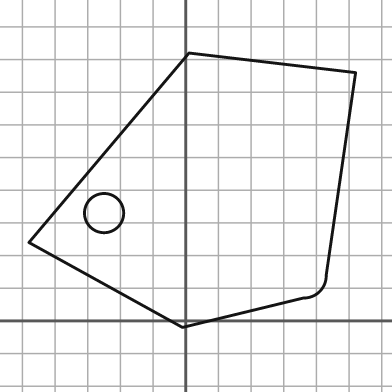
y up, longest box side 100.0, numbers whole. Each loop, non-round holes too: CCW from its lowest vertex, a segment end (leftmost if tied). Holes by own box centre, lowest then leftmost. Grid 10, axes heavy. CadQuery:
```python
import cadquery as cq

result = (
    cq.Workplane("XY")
    .moveTo(-1.0, -2.0)
    .lineTo(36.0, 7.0)
    .threePointArc((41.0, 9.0), (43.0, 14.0))
    .lineTo(52.0, 76.0)
    .lineTo(1.0, 82.0)
    .lineTo(-48.0, 24.0)
    .close()
    .moveTo(-25.0, 33.0)
    .circle(6.0)
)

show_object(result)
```